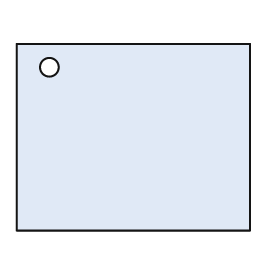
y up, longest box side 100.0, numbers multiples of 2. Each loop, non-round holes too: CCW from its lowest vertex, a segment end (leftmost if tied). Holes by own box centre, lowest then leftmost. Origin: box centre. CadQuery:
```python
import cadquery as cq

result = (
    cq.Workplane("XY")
    .moveTo(-50.0, -40.0)
    .lineTo(50.0, -40.0)
    .lineTo(50.0, 40.0)
    .lineTo(-50.0, 40.0)
    .close()
    .moveTo(-36.0, 30.0)
    .circle(4.0)
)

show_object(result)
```